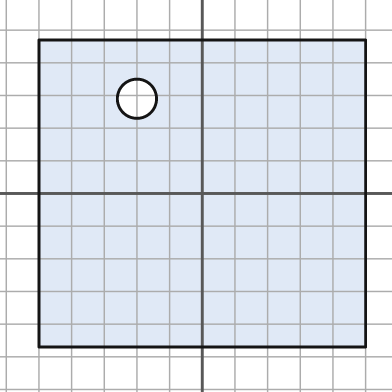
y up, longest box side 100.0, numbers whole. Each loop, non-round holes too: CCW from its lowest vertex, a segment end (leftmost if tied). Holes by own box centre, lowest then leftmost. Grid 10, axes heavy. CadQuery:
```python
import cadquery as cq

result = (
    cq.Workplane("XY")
    .moveTo(-50.0, -47.0)
    .lineTo(50.0, -47.0)
    .lineTo(50.0, 47.0)
    .lineTo(-50.0, 47.0)
    .close()
    .moveTo(-20.0, 29.0)
    .circle(6.0)
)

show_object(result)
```